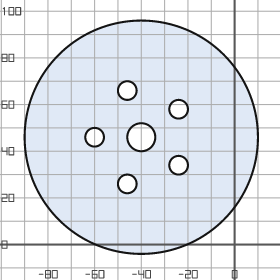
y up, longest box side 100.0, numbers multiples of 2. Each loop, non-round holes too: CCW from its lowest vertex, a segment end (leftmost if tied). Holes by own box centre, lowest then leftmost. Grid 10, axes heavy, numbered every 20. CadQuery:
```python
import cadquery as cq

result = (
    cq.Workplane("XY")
    .moveTo(-40.0, 46.0)
    .circle(50.0)
    .moveTo(-46.0, 26.0)
    .circle(4.0)
    .moveTo(-24.0, 34.0)
    .circle(4.0)
    .moveTo(-60.0, 46.0)
    .circle(4.0)
    .moveTo(-40.0, 46.0)
    .circle(6.0)
    .moveTo(-24.0, 58.0)
    .circle(4.0)
    .moveTo(-46.0, 66.0)
    .circle(4.0)
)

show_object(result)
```